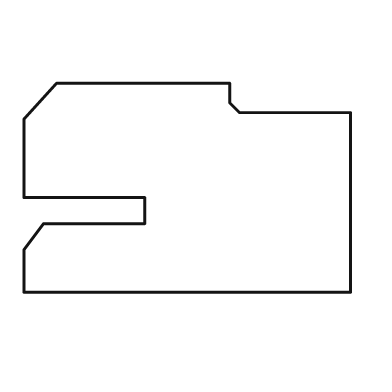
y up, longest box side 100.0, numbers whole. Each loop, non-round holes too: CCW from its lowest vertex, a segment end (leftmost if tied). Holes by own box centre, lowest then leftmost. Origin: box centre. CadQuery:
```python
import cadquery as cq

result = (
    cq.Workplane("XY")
    .moveTo(-50.0, -32.0)
    .lineTo(50.0, -32.0)
    .lineTo(50.0, 23.0)
    .lineTo(16.0, 23.0)
    .lineTo(13.0, 26.0)
    .lineTo(13.0, 32.0)
    .lineTo(-40.0, 32.0)
    .lineTo(-50.0, 21.0)
    .lineTo(-50.0, -3.0)
    .lineTo(-13.0, -3.0)
    .lineTo(-13.0, -11.0)
    .lineTo(-44.0, -11.0)
    .lineTo(-50.0, -19.0)
    .close()
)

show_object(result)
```